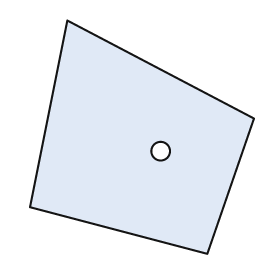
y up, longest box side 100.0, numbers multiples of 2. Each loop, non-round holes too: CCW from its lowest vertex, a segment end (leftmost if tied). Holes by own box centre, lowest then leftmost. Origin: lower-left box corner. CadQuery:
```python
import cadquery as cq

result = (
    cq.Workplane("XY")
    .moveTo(76.0, 0.0)
    .lineTo(96.0, 58.0)
    .lineTo(16.0, 100.0)
    .lineTo(0.0, 20.0)
    .close()
    .moveTo(56.0, 44.0)
    .circle(4.0)
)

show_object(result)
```